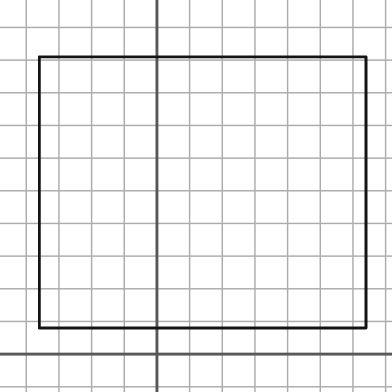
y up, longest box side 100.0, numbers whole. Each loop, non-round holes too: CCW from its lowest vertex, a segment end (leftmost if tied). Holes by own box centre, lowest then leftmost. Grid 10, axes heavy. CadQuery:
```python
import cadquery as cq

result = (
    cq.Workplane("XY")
    .moveTo(-36.0, 8.0)
    .lineTo(64.0, 8.0)
    .lineTo(64.0, 91.0)
    .lineTo(-36.0, 91.0)
    .close()
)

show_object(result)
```